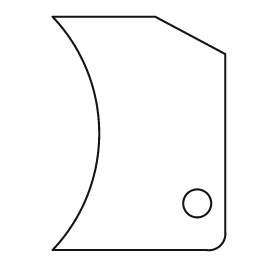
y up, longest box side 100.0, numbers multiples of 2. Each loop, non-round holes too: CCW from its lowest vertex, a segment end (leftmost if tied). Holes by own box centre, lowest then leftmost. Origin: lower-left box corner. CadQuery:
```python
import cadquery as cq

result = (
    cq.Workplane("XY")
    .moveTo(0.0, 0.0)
    .lineTo(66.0, 0.0)
    .threePointArc((72.0, 2.0), (74.0, 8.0))
    .lineTo(74.0, 84.0)
    .lineTo(44.0, 100.0)
    .lineTo(0.0, 100.0)
    .threePointArc((20.0, 50.0), (0.0, 0.0))
    .close()
    .moveTo(62.0, 20.0)
    .circle(6.0)
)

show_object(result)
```